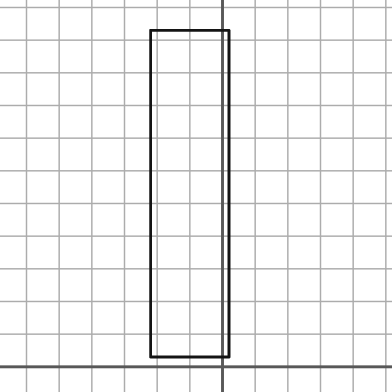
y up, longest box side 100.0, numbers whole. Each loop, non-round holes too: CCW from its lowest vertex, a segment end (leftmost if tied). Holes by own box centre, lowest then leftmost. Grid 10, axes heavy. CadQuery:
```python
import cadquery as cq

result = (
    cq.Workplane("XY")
    .moveTo(-22.0, 3.0)
    .lineTo(2.0, 3.0)
    .lineTo(2.0, 103.0)
    .lineTo(-22.0, 103.0)
    .close()
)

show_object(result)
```